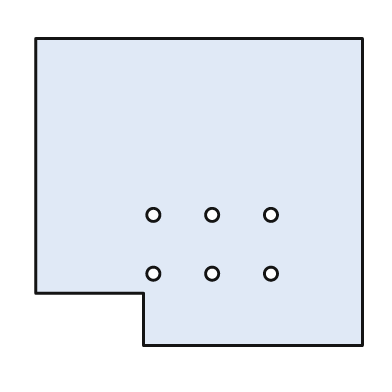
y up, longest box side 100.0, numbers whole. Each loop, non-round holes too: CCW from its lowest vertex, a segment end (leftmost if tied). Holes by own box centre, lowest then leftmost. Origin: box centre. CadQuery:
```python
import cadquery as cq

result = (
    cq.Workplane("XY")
    .moveTo(-17.0, -47.0)
    .lineTo(50.0, -47.0)
    .lineTo(50.0, 47.0)
    .lineTo(-50.0, 47.0)
    .lineTo(-50.0, -31.0)
    .lineTo(-17.0, -31.0)
    .close()
    .moveTo(-14.0, -25.0)
    .circle(2.0)
    .moveTo(4.0, -25.0)
    .circle(2.0)
    .moveTo(22.0, -25.0)
    .circle(2.0)
    .moveTo(-14.0, -7.0)
    .circle(2.0)
    .moveTo(4.0, -7.0)
    .circle(2.0)
    .moveTo(22.0, -7.0)
    .circle(2.0)
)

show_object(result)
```